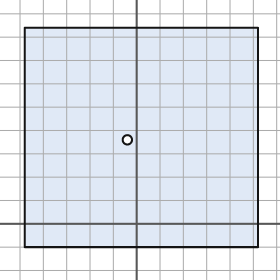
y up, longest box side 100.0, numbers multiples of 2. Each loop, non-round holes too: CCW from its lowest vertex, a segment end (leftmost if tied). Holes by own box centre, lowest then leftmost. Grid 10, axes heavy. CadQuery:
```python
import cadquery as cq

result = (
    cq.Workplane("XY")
    .moveTo(-48.0, -10.0)
    .lineTo(52.0, -10.0)
    .lineTo(52.0, 84.0)
    .lineTo(-48.0, 84.0)
    .close()
    .moveTo(-4.0, 36.0)
    .circle(2.0)
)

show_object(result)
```